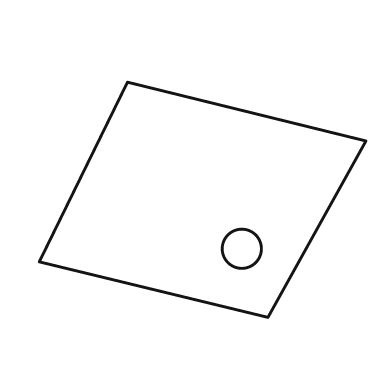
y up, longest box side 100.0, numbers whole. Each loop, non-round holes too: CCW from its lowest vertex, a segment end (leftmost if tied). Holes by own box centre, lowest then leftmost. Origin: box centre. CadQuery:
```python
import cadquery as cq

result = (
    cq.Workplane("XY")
    .moveTo(20.0, -36.0)
    .lineTo(50.0, 18.0)
    .lineTo(-23.0, 36.0)
    .lineTo(-50.0, -19.0)
    .close()
    .moveTo(12.0, -15.0)
    .circle(6.0)
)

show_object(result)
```